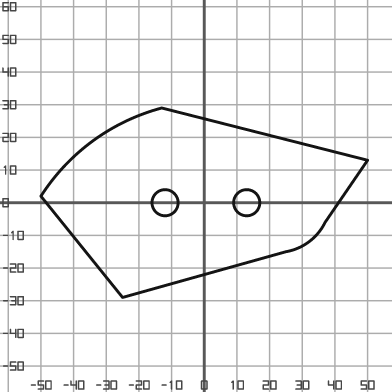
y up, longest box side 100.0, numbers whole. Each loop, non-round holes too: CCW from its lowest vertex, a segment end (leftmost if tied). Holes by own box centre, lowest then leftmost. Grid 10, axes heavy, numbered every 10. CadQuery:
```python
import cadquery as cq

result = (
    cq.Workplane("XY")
    .moveTo(-25.0, -29.0)
    .lineTo(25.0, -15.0)
    .threePointArc((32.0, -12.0), (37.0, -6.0))
    .lineTo(50.0, 13.0)
    .lineTo(-13.0, 29.0)
    .threePointArc((-34.0, 19.0), (-50.0, 2.0))
    .close()
    .moveTo(-12.0, 0.0)
    .circle(4.0)
    .moveTo(13.0, 0.0)
    .circle(4.0)
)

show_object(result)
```